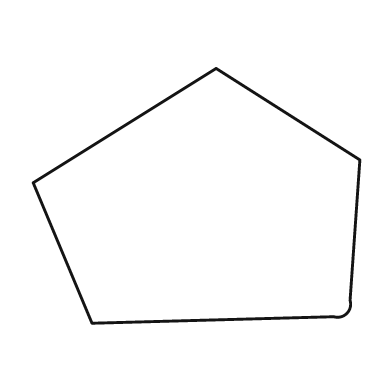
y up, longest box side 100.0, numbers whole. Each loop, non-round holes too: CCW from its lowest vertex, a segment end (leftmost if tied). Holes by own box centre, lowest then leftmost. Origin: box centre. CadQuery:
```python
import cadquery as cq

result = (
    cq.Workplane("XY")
    .moveTo(-32.0, -39.0)
    .lineTo(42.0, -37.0)
    .threePointArc((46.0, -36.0), (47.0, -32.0))
    .lineTo(50.0, 11.0)
    .lineTo(6.0, 39.0)
    .lineTo(-50.0, 4.0)
    .close()
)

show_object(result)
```